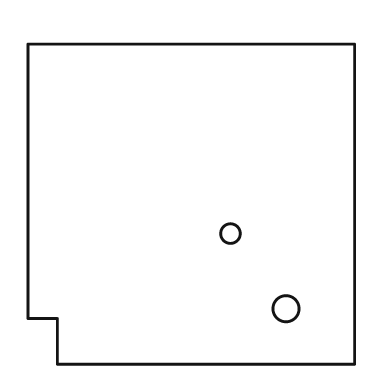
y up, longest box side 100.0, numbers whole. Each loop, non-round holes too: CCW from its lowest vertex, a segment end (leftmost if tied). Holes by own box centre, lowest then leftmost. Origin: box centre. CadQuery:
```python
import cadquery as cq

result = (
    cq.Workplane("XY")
    .moveTo(-41.0, -49.0)
    .lineTo(50.0, -49.0)
    .lineTo(50.0, 49.0)
    .lineTo(-50.0, 49.0)
    .lineTo(-50.0, -35.0)
    .lineTo(-41.0, -35.0)
    .close()
    .moveTo(29.0, -32.0)
    .circle(4.0)
    .moveTo(12.0, -9.0)
    .circle(3.0)
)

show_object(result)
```